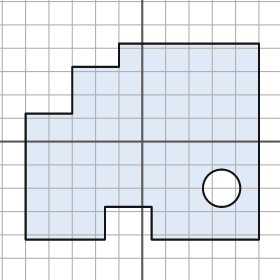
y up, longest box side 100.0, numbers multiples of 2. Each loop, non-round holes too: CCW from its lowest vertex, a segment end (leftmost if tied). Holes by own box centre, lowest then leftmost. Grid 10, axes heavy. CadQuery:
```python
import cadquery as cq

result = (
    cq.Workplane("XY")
    .moveTo(-50.0, -42.0)
    .lineTo(-16.0, -42.0)
    .lineTo(-16.0, -28.0)
    .lineTo(4.0, -28.0)
    .lineTo(4.0, -42.0)
    .lineTo(50.0, -42.0)
    .lineTo(50.0, 42.0)
    .lineTo(-10.0, 42.0)
    .lineTo(-10.0, 32.0)
    .lineTo(-30.0, 32.0)
    .lineTo(-30.0, 12.0)
    .lineTo(-50.0, 12.0)
    .close()
    .moveTo(34.0, -20.0)
    .circle(8.0)
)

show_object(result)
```